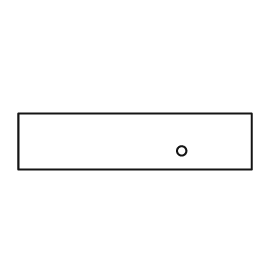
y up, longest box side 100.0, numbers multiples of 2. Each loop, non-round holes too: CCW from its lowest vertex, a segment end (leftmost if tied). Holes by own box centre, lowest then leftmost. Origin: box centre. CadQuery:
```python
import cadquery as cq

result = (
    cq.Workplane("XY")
    .moveTo(-50.0, -12.0)
    .lineTo(50.0, -12.0)
    .lineTo(50.0, 12.0)
    .lineTo(-50.0, 12.0)
    .close()
    .moveTo(20.0, -4.0)
    .circle(2.0)
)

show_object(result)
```